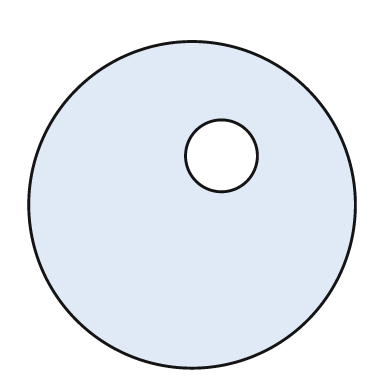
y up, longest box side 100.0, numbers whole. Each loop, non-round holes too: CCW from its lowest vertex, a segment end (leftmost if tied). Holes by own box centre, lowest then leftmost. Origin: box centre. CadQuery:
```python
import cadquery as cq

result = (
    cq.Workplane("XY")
    .moveTo(0.0, 0.0)
    .circle(50.0)
    .moveTo(9.0, 15.0)
    .circle(11.0)
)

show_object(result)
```